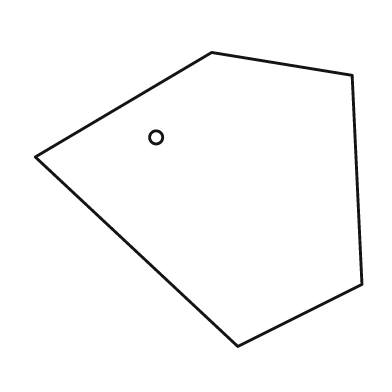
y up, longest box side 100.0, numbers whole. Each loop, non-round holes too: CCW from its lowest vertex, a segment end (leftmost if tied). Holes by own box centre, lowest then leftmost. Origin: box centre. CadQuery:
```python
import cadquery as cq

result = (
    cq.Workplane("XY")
    .moveTo(12.0, -45.0)
    .lineTo(50.0, -26.0)
    .lineTo(47.0, 38.0)
    .lineTo(4.0, 45.0)
    .lineTo(-50.0, 13.0)
    .close()
    .moveTo(-13.0, 19.0)
    .circle(2.0)
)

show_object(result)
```